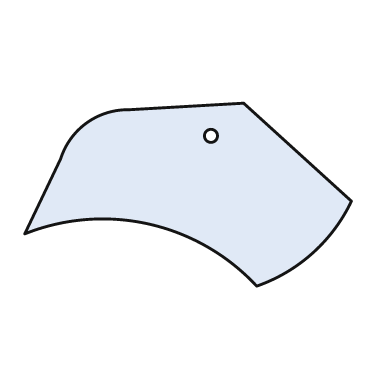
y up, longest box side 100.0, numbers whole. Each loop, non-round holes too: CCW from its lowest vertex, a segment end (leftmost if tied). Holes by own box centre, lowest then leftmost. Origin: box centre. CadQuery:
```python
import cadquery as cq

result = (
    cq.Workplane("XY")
    .moveTo(21.0, -28.0)
    .threePointArc((38.0, -18.0), (50.0, -2.0))
    .lineTo(17.0, 28.0)
    .lineTo(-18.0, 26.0)
    .threePointArc((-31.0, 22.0), (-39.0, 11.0))
    .lineTo(-50.0, -12.0)
    .threePointArc((-12.0, -9.0), (21.0, -28.0))
    .close()
    .moveTo(7.0, 18.0)
    .circle(2.0)
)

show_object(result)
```